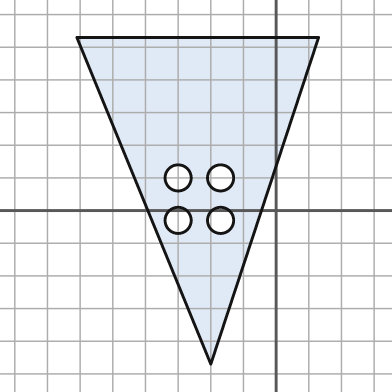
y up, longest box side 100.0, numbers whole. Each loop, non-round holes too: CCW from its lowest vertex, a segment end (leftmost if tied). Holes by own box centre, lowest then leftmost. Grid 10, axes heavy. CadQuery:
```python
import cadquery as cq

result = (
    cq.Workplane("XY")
    .moveTo(-20.0, -47.0)
    .lineTo(13.0, 53.0)
    .lineTo(-61.0, 53.0)
    .close()
    .moveTo(-30.0, -3.0)
    .circle(4.0)
    .moveTo(-17.0, -3.0)
    .circle(4.0)
    .moveTo(-30.0, 10.0)
    .circle(4.0)
    .moveTo(-17.0, 10.0)
    .circle(4.0)
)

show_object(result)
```